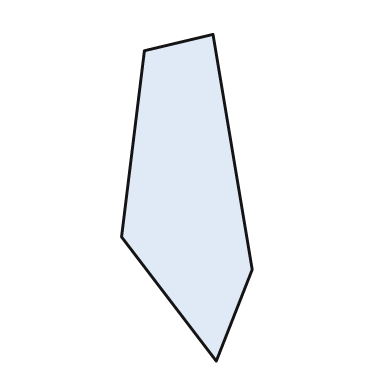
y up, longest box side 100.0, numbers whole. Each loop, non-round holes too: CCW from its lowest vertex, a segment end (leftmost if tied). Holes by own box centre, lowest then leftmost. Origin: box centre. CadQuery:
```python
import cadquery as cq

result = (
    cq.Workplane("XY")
    .moveTo(9.0, -50.0)
    .lineTo(20.0, -22.0)
    .lineTo(8.0, 50.0)
    .lineTo(-13.0, 45.0)
    .lineTo(-20.0, -12.0)
    .close()
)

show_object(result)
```